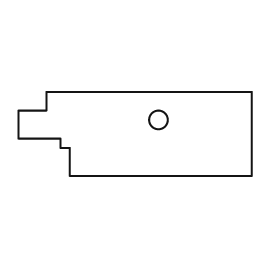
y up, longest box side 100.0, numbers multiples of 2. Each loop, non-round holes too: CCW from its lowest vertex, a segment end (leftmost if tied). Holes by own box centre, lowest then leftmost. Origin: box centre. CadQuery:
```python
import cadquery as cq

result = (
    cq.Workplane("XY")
    .moveTo(-28.0, -18.0)
    .lineTo(50.0, -18.0)
    .lineTo(50.0, 18.0)
    .lineTo(-38.0, 18.0)
    .lineTo(-38.0, 10.0)
    .lineTo(-50.0, 10.0)
    .lineTo(-50.0, -2.0)
    .lineTo(-32.0, -2.0)
    .lineTo(-32.0, -6.0)
    .lineTo(-28.0, -6.0)
    .close()
    .moveTo(10.0, 6.0)
    .circle(4.0)
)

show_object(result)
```